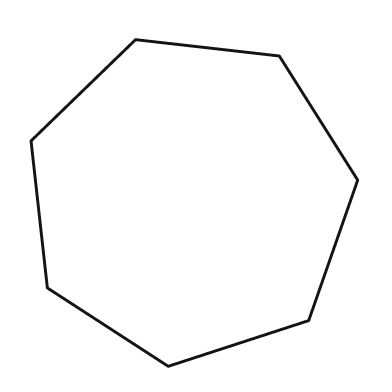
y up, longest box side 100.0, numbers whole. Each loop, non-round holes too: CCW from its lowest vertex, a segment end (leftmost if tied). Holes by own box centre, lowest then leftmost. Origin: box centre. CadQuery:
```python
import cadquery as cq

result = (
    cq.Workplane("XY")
    .moveTo(-8.0, -50.0)
    .lineTo(35.0, -36.0)
    .lineTo(50.0, 7.0)
    .lineTo(26.0, 45.0)
    .lineTo(-18.0, 50.0)
    .lineTo(-50.0, 19.0)
    .lineTo(-45.0, -26.0)
    .close()
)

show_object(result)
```